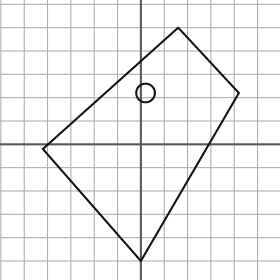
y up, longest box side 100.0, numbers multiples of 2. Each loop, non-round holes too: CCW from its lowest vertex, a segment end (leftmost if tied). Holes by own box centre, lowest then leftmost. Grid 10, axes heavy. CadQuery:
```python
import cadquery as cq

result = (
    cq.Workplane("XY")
    .moveTo(0.0, -50.0)
    .lineTo(42.0, 22.0)
    .lineTo(16.0, 50.0)
    .lineTo(-42.0, -2.0)
    .close()
    .moveTo(2.0, 22.0)
    .circle(4.0)
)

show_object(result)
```